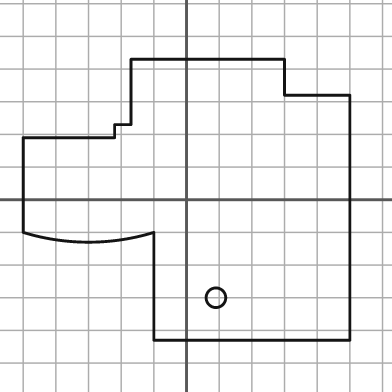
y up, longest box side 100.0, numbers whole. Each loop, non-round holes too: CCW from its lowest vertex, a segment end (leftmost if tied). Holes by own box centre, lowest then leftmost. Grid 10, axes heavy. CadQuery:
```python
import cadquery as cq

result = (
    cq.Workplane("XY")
    .moveTo(-10.0, -43.0)
    .lineTo(50.0, -43.0)
    .lineTo(50.0, 32.0)
    .lineTo(30.0, 32.0)
    .lineTo(30.0, 43.0)
    .lineTo(-17.0, 43.0)
    .lineTo(-17.0, 23.0)
    .lineTo(-22.0, 23.0)
    .lineTo(-22.0, 19.0)
    .lineTo(-50.0, 19.0)
    .lineTo(-50.0, -10.0)
    .threePointArc((-30.0, -13.0), (-10.0, -10.0))
    .close()
    .moveTo(9.0, -30.0)
    .circle(3.0)
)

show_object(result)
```